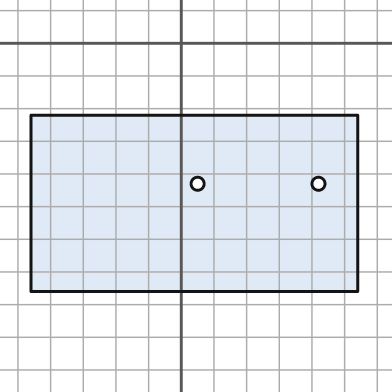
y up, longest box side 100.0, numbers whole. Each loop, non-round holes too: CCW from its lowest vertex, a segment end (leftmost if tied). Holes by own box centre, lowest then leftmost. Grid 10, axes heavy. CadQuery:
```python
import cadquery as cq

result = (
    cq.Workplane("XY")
    .moveTo(-46.0, -76.0)
    .lineTo(54.0, -76.0)
    .lineTo(54.0, -22.0)
    .lineTo(-46.0, -22.0)
    .close()
    .moveTo(5.0, -43.0)
    .circle(2.0)
    .moveTo(42.0, -43.0)
    .circle(2.0)
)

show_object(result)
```